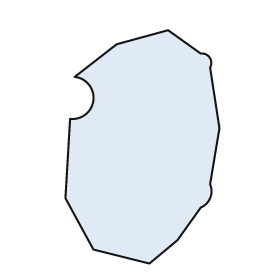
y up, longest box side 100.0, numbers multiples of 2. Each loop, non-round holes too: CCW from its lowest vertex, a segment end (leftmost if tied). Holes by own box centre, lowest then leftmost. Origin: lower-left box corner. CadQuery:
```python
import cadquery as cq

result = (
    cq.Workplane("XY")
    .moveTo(36.0, 0.0)
    .lineTo(48.0, 10.0)
    .lineTo(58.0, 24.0)
    .threePointArc((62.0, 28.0), (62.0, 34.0))
    .lineTo(66.0, 58.0)
    .lineTo(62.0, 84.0)
    .threePointArc((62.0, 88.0), (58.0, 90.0))
    .lineTo(44.0, 100.0)
    .lineTo(22.0, 94.0)
    .lineTo(4.0, 80.0)
    .threePointArc((12.0, 70.0), (2.0, 62.0))
    .lineTo(0.0, 28.0)
    .lineTo(12.0, 6.0)
    .close()
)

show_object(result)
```